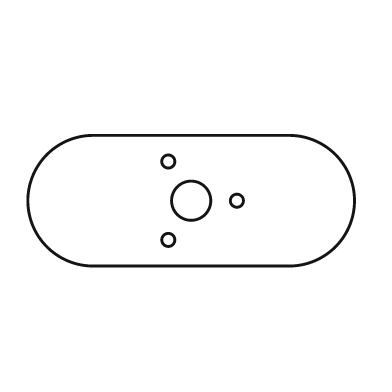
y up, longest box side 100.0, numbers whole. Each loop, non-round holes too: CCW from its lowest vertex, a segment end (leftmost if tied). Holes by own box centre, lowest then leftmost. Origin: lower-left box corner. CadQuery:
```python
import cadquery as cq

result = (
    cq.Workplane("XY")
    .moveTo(20.0, 0.0)
    .lineTo(80.0, 0.0)
    .threePointArc((100.0, 20.0), (80.0, 40.0))
    .lineTo(20.0, 40.0)
    .threePointArc((0.0, 20.0), (20.0, 0.0))
    .close()
    .moveTo(43.0, 8.0)
    .circle(2.0)
    .moveTo(50.0, 20.0)
    .circle(6.0)
    .moveTo(64.0, 20.0)
    .circle(2.0)
    .moveTo(43.0, 32.0)
    .circle(2.0)
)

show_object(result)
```